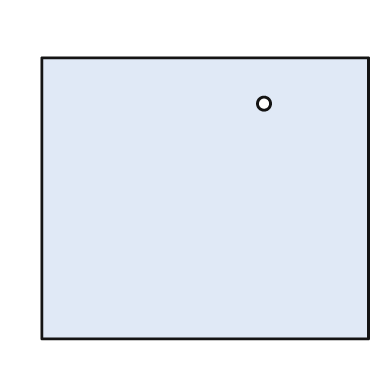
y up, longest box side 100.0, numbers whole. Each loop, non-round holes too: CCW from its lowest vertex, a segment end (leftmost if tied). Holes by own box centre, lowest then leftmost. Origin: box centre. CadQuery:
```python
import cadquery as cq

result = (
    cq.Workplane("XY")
    .moveTo(-50.0, -43.0)
    .lineTo(50.0, -43.0)
    .lineTo(50.0, 43.0)
    .lineTo(-50.0, 43.0)
    .close()
    .moveTo(18.0, 29.0)
    .circle(2.0)
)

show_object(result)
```